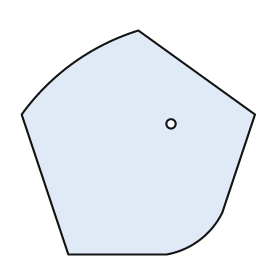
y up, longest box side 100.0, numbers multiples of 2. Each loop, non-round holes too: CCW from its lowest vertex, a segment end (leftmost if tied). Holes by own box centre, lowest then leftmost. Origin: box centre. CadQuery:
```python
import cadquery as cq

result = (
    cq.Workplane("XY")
    .moveTo(-30.0, -48.0)
    .lineTo(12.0, -48.0)
    .threePointArc((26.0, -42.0), (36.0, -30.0))
    .lineTo(50.0, 12.0)
    .lineTo(0.0, 48.0)
    .threePointArc((-28.0, 34.0), (-50.0, 12.0))
    .close()
    .moveTo(14.0, 8.0)
    .circle(2.0)
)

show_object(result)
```